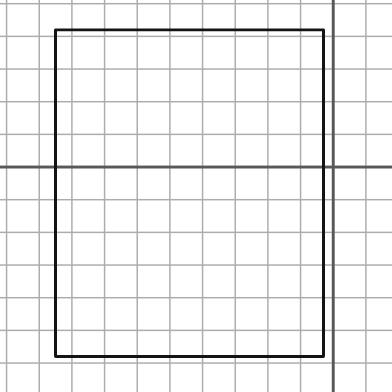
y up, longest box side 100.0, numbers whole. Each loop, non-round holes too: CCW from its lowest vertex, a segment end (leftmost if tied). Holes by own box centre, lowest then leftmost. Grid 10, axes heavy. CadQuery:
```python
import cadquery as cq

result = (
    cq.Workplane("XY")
    .moveTo(-85.0, -58.0)
    .lineTo(-3.0, -58.0)
    .lineTo(-3.0, 42.0)
    .lineTo(-85.0, 42.0)
    .close()
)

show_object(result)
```